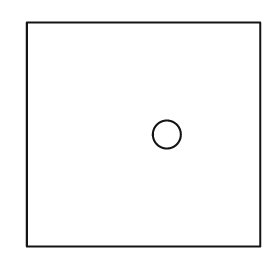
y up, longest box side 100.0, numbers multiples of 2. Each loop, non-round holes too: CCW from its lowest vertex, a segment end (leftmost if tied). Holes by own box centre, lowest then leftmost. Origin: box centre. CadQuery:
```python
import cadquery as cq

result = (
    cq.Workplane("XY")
    .moveTo(-50.0, -48.0)
    .lineTo(50.0, -48.0)
    .lineTo(50.0, 48.0)
    .lineTo(-50.0, 48.0)
    .close()
    .moveTo(10.0, 0.0)
    .circle(6.0)
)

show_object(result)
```